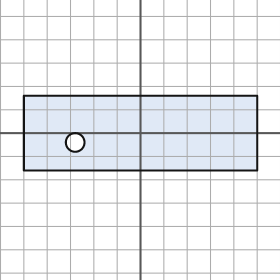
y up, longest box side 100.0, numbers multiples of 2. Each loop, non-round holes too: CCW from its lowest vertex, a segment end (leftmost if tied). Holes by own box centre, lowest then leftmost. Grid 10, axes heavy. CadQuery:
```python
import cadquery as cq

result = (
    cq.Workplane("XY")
    .moveTo(-50.0, -16.0)
    .lineTo(50.0, -16.0)
    .lineTo(50.0, 16.0)
    .lineTo(-50.0, 16.0)
    .close()
    .moveTo(-28.0, -4.0)
    .circle(4.0)
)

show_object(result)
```